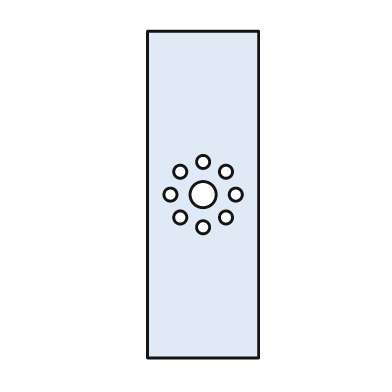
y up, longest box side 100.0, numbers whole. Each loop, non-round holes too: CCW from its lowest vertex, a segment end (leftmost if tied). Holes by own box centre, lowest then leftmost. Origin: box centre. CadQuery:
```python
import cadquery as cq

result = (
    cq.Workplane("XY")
    .moveTo(-17.0, -50.0)
    .lineTo(17.0, -50.0)
    .lineTo(17.0, 50.0)
    .lineTo(-17.0, 50.0)
    .close()
    .moveTo(0.0, -10.0)
    .circle(2.0)
    .moveTo(-7.0, -7.0)
    .circle(2.0)
    .moveTo(7.0, -7.0)
    .circle(2.0)
    .moveTo(-10.0, 0.0)
    .circle(2.0)
    .moveTo(0.0, 0.0)
    .circle(4.0)
    .moveTo(10.0, 0.0)
    .circle(2.0)
    .moveTo(-7.0, 7.0)
    .circle(2.0)
    .moveTo(7.0, 7.0)
    .circle(2.0)
    .moveTo(0.0, 10.0)
    .circle(2.0)
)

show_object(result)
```